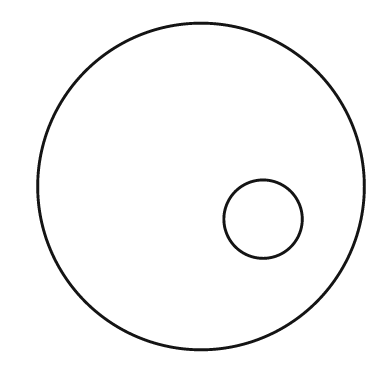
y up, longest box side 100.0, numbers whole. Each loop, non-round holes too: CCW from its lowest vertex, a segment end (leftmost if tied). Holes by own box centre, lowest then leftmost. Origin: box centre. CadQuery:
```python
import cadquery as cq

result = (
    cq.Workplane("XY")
    .moveTo(0.0, 0.0)
    .circle(50.0)
    .moveTo(19.0, -10.0)
    .circle(12.0)
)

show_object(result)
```